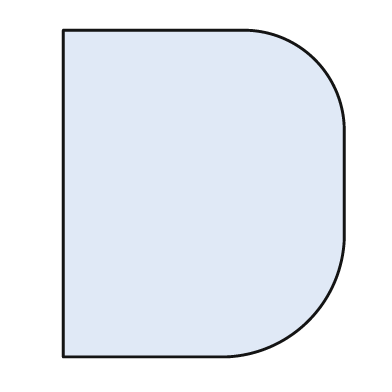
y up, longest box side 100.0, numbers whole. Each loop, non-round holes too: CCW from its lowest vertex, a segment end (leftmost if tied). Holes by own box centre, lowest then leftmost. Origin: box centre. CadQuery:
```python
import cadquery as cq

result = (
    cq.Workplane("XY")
    .moveTo(-43.0, -50.0)
    .lineTo(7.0, -50.0)
    .threePointArc((32.0, -39.0), (43.0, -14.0))
    .lineTo(43.0, 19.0)
    .threePointArc((34.0, 41.0), (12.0, 50.0))
    .lineTo(-43.0, 50.0)
    .close()
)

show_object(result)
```